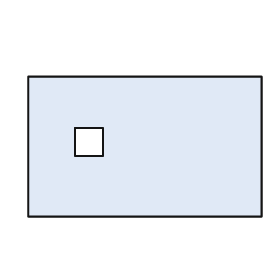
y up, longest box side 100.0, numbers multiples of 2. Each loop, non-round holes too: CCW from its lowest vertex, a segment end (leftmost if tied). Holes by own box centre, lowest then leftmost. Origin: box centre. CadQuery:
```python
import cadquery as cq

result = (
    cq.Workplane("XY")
    .moveTo(-50.0, -30.0)
    .lineTo(50.0, -30.0)
    .lineTo(50.0, 30.0)
    .lineTo(-50.0, 30.0)
    .close()
    .moveTo(-30.0, -4.0)
    .lineTo(-18.0, -4.0)
    .lineTo(-18.0, 8.0)
    .lineTo(-30.0, 8.0)
    .close()
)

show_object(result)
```